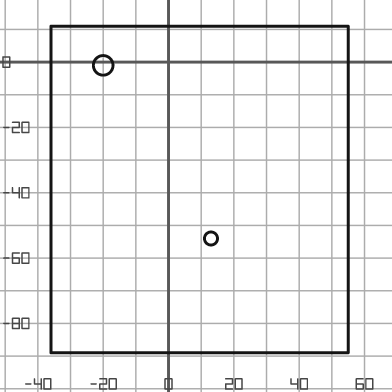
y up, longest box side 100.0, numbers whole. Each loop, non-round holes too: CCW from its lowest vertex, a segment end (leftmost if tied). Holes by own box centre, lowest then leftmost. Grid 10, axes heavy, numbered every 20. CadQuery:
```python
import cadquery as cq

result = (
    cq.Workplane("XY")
    .moveTo(-36.0, -89.0)
    .lineTo(55.0, -89.0)
    .lineTo(55.0, 11.0)
    .lineTo(-36.0, 11.0)
    .close()
    .moveTo(13.0, -54.0)
    .circle(2.0)
    .moveTo(-20.0, -1.0)
    .circle(3.0)
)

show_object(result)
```